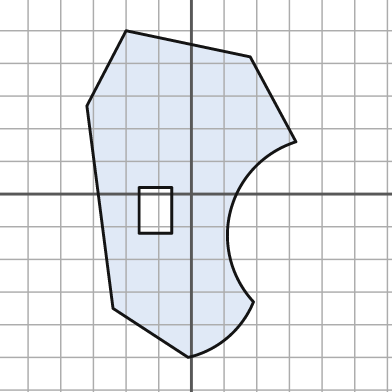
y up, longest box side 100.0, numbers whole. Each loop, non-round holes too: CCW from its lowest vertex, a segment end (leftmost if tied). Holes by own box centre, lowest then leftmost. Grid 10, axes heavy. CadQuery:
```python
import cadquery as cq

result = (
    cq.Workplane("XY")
    .moveTo(-1.0, -50.0)
    .threePointArc((11.0, -44.0), (19.0, -33.0))
    .threePointArc((12.0, -5.0), (32.0, 16.0))
    .lineTo(18.0, 42.0)
    .lineTo(-20.0, 50.0)
    .lineTo(-32.0, 27.0)
    .lineTo(-24.0, -35.0)
    .close()
    .moveTo(-16.0, -12.0)
    .lineTo(-6.0, -12.0)
    .lineTo(-6.0, 2.0)
    .lineTo(-16.0, 2.0)
    .close()
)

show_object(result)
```